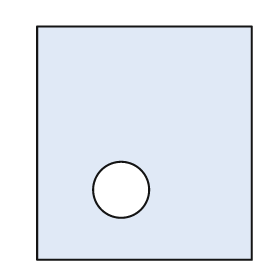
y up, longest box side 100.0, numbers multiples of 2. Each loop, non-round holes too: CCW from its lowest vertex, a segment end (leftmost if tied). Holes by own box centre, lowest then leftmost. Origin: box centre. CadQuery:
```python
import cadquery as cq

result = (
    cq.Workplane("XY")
    .moveTo(-46.0, -50.0)
    .lineTo(46.0, -50.0)
    .lineTo(46.0, 50.0)
    .lineTo(-46.0, 50.0)
    .close()
    .moveTo(-10.0, -20.0)
    .circle(12.0)
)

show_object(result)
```